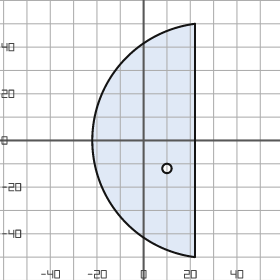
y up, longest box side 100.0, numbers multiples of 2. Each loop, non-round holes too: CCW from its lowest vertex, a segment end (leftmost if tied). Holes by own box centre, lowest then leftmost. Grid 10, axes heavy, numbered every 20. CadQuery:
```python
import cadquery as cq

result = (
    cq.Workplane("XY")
    .moveTo(22.0, -50.0)
    .lineTo(22.0, 50.0)
    .threePointArc((-22.0, 0.0), (22.0, -50.0))
    .close()
    .moveTo(10.0, -12.0)
    .circle(2.0)
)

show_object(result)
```